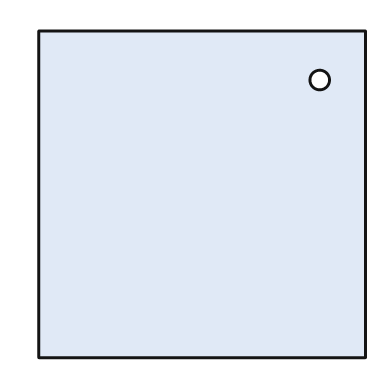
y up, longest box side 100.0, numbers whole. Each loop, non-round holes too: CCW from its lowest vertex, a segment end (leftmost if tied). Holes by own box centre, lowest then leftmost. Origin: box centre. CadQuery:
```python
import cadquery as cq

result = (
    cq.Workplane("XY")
    .moveTo(-50.0, -50.0)
    .lineTo(50.0, -50.0)
    .lineTo(50.0, 50.0)
    .lineTo(-50.0, 50.0)
    .close()
    .moveTo(36.0, 35.0)
    .circle(3.0)
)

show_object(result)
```